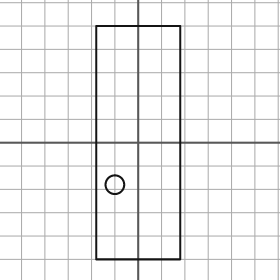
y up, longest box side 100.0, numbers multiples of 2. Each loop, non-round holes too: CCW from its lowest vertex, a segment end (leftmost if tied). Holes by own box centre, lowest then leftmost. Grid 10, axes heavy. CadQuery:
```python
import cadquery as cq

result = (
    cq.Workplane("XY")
    .moveTo(-18.0, -50.0)
    .lineTo(18.0, -50.0)
    .lineTo(18.0, 50.0)
    .lineTo(-18.0, 50.0)
    .close()
    .moveTo(-10.0, -18.0)
    .circle(4.0)
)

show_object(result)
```